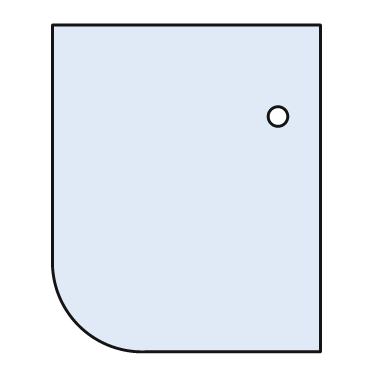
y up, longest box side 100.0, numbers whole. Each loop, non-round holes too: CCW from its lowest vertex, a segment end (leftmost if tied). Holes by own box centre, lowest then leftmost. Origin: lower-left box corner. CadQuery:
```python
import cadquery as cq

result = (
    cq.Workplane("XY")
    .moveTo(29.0, 0.0)
    .lineTo(82.0, 0.0)
    .lineTo(82.0, 100.0)
    .lineTo(0.0, 100.0)
    .lineTo(0.0, 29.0)
    .threePointArc((8.0, 8.0), (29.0, 0.0))
    .close()
    .moveTo(69.0, 72.0)
    .circle(3.0)
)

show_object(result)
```